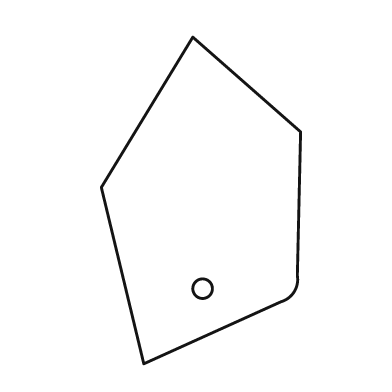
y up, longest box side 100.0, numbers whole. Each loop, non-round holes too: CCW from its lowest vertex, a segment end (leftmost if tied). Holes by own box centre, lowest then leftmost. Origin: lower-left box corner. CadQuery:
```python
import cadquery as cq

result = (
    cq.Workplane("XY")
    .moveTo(13.0, 0.0)
    .lineTo(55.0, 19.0)
    .threePointArc((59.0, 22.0), (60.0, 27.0))
    .lineTo(61.0, 71.0)
    .lineTo(28.0, 100.0)
    .lineTo(0.0, 54.0)
    .close()
    .moveTo(31.0, 23.0)
    .circle(3.0)
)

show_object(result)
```